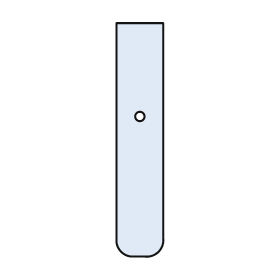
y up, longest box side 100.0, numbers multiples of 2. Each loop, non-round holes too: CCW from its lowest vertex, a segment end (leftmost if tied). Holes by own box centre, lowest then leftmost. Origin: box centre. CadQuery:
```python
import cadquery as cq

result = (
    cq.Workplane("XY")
    .moveTo(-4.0, -50.0)
    .lineTo(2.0, -50.0)
    .threePointArc((8.0, -48.0), (10.0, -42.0))
    .lineTo(10.0, 50.0)
    .lineTo(-10.0, 50.0)
    .lineTo(-10.0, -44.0)
    .threePointArc((-8.0, -48.0), (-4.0, -50.0))
    .close()
    .moveTo(0.0, 10.0)
    .circle(2.0)
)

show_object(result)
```